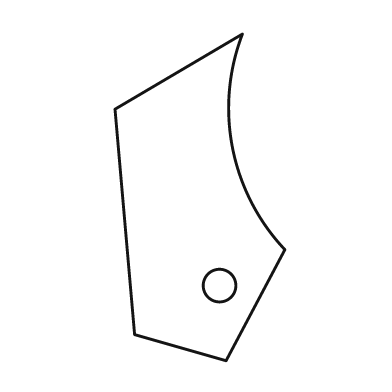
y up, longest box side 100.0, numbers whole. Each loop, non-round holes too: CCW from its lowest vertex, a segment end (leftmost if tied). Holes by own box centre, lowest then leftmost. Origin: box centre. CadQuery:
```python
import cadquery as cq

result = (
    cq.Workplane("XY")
    .moveTo(8.0, -50.0)
    .lineTo(26.0, -16.0)
    .threePointArc((10.0, 15.0), (13.0, 50.0))
    .lineTo(-26.0, 27.0)
    .lineTo(-20.0, -42.0)
    .close()
    .moveTo(6.0, -27.0)
    .circle(5.0)
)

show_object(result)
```